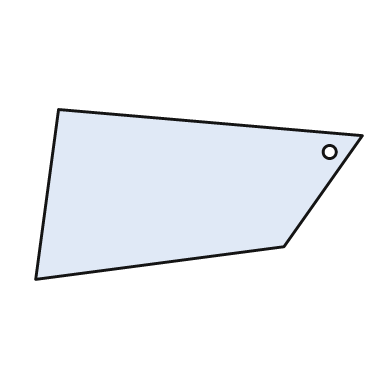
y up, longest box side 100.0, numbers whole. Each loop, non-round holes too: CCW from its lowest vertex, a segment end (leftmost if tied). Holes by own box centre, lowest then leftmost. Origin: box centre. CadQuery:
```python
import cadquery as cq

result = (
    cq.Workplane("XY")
    .moveTo(-50.0, -26.0)
    .lineTo(26.0, -16.0)
    .lineTo(50.0, 18.0)
    .lineTo(-43.0, 26.0)
    .close()
    .moveTo(40.0, 13.0)
    .circle(2.0)
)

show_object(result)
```